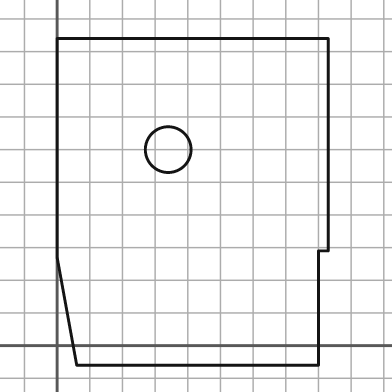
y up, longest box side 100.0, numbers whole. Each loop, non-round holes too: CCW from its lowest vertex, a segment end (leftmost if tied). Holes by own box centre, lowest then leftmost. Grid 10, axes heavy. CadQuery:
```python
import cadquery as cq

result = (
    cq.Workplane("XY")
    .moveTo(6.0, -6.0)
    .lineTo(80.0, -6.0)
    .lineTo(80.0, 29.0)
    .lineTo(83.0, 29.0)
    .lineTo(83.0, 94.0)
    .lineTo(0.0, 94.0)
    .lineTo(0.0, 27.0)
    .close()
    .moveTo(34.0, 60.0)
    .circle(7.0)
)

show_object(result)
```